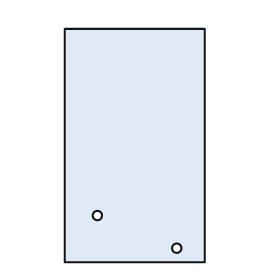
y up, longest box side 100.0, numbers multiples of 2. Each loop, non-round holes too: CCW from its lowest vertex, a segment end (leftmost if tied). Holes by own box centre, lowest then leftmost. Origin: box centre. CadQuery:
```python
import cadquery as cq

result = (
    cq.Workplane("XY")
    .moveTo(-30.0, -50.0)
    .lineTo(30.0, -50.0)
    .lineTo(30.0, 50.0)
    .lineTo(-30.0, 50.0)
    .close()
    .moveTo(18.0, -44.0)
    .circle(2.0)
    .moveTo(-16.0, -30.0)
    .circle(2.0)
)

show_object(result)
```